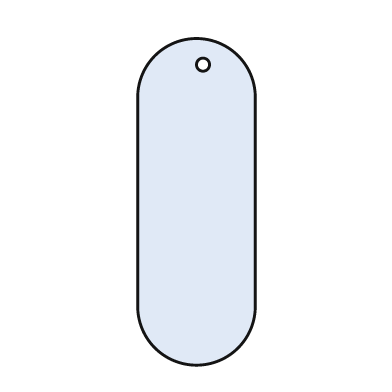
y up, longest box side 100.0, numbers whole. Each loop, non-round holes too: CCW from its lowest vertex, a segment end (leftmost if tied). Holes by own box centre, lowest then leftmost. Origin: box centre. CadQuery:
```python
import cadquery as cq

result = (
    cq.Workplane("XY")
    .moveTo(-18.0, -32.0)
    .threePointArc((0.0, -50.0), (18.0, -32.0))
    .lineTo(18.0, 32.0)
    .threePointArc((0.0, 50.0), (-18.0, 32.0))
    .close()
    .moveTo(2.0, 42.0)
    .circle(2.0)
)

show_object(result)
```